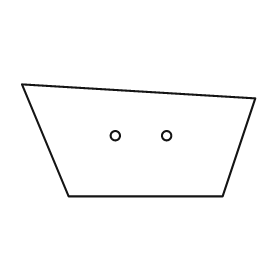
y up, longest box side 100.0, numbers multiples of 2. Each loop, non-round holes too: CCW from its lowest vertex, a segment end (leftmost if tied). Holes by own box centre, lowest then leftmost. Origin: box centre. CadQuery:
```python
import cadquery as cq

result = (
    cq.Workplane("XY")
    .moveTo(-30.0, -24.0)
    .lineTo(36.0, -24.0)
    .lineTo(50.0, 18.0)
    .lineTo(-50.0, 24.0)
    .close()
    .moveTo(-10.0, 2.0)
    .circle(2.0)
    .moveTo(12.0, 2.0)
    .circle(2.0)
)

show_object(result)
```